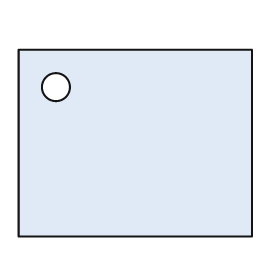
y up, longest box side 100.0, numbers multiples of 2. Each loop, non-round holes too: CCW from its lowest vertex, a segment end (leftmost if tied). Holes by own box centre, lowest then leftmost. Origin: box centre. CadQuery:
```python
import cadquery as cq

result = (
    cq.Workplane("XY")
    .moveTo(-50.0, -40.0)
    .lineTo(50.0, -40.0)
    .lineTo(50.0, 40.0)
    .lineTo(-50.0, 40.0)
    .close()
    .moveTo(-34.0, 24.0)
    .circle(6.0)
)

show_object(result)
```